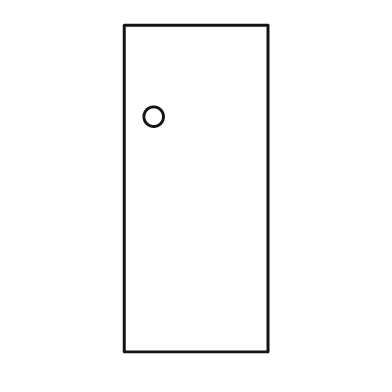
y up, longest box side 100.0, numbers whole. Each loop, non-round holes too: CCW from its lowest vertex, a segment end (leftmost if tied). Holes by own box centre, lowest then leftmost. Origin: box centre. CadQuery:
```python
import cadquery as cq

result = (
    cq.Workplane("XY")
    .moveTo(-22.0, -50.0)
    .lineTo(22.0, -50.0)
    .lineTo(22.0, 50.0)
    .lineTo(-22.0, 50.0)
    .close()
    .moveTo(-13.0, 22.0)
    .circle(3.0)
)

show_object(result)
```